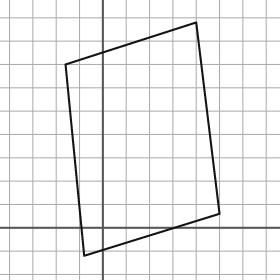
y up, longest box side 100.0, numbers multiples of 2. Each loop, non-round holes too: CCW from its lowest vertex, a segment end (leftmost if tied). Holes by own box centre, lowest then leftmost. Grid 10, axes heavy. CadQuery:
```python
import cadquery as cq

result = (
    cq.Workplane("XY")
    .moveTo(-8.0, -12.0)
    .lineTo(50.0, 6.0)
    .lineTo(40.0, 88.0)
    .lineTo(-16.0, 70.0)
    .close()
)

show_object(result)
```